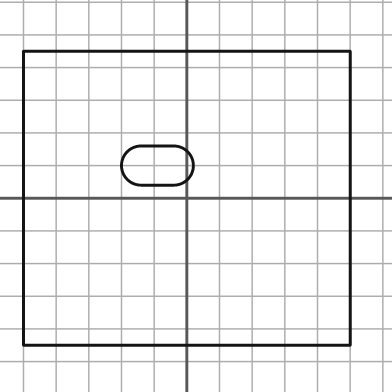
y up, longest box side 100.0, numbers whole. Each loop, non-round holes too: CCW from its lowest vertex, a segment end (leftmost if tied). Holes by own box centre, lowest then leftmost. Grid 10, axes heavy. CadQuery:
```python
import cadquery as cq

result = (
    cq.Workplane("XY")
    .moveTo(-50.0, -45.0)
    .lineTo(50.0, -45.0)
    .lineTo(50.0, 45.0)
    .lineTo(-50.0, 45.0)
    .close()
    .moveTo(-14.0, 4.0)
    .lineTo(-4.0, 4.0)
    .threePointArc((2.0, 10.0), (-4.0, 16.0))
    .lineTo(-14.0, 16.0)
    .threePointArc((-20.0, 10.0), (-14.0, 4.0))
    .close()
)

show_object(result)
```